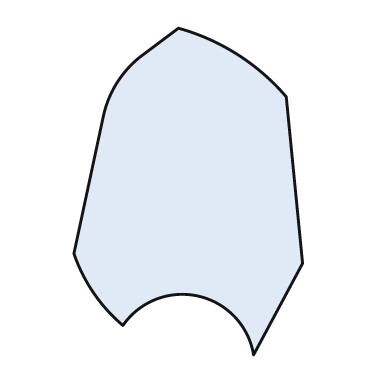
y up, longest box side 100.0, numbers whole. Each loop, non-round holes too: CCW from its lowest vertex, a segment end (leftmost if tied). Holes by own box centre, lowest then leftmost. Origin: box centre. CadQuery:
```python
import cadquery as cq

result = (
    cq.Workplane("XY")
    .moveTo(20.0, -50.0)
    .lineTo(35.0, -22.0)
    .lineTo(30.0, 29.0)
    .threePointArc((15.0, 42.0), (-3.0, 50.0))
    .lineTo(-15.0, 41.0)
    .threePointArc((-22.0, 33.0), (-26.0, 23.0))
    .lineTo(-35.0, -19.0)
    .threePointArc((-29.0, -31.0), (-20.0, -41.0))
    .threePointArc((3.0, -32.0), (20.0, -50.0))
    .close()
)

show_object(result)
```